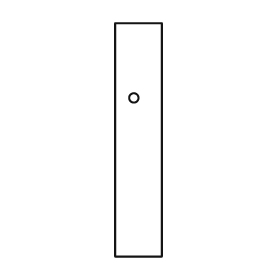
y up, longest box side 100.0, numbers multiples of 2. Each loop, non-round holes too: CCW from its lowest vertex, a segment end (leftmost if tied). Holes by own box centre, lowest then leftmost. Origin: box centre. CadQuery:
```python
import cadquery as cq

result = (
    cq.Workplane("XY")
    .moveTo(-10.0, -50.0)
    .lineTo(10.0, -50.0)
    .lineTo(10.0, 50.0)
    .lineTo(-10.0, 50.0)
    .close()
    .moveTo(-2.0, 18.0)
    .circle(2.0)
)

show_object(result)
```